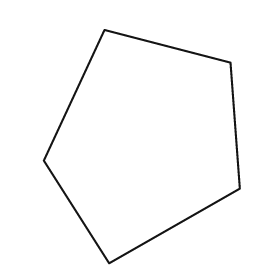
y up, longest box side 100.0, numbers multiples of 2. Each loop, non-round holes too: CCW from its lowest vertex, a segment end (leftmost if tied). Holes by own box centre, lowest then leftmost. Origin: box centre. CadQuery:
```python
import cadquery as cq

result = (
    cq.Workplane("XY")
    .moveTo(-14.0, -50.0)
    .lineTo(42.0, -18.0)
    .lineTo(38.0, 36.0)
    .lineTo(-16.0, 50.0)
    .lineTo(-42.0, -6.0)
    .close()
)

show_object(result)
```